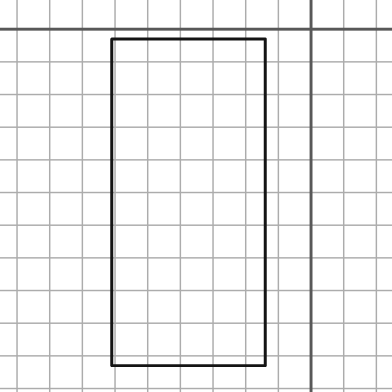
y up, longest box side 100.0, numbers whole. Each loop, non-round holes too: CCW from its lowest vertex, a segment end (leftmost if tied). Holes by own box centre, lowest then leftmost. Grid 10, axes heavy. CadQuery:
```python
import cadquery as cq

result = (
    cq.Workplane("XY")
    .moveTo(-61.0, -103.0)
    .lineTo(-14.0, -103.0)
    .lineTo(-14.0, -3.0)
    .lineTo(-61.0, -3.0)
    .close()
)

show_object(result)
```